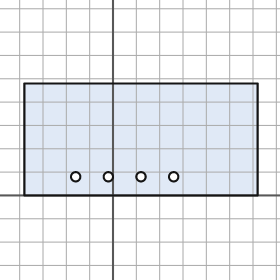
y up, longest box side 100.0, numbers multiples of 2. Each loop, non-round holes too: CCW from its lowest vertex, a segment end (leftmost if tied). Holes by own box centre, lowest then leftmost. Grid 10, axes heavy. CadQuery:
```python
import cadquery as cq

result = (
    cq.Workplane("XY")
    .moveTo(-38.0, 0.0)
    .lineTo(62.0, 0.0)
    .lineTo(62.0, 48.0)
    .lineTo(-38.0, 48.0)
    .close()
    .moveTo(-16.0, 8.0)
    .circle(2.0)
    .moveTo(-2.0, 8.0)
    .circle(2.0)
    .moveTo(12.0, 8.0)
    .circle(2.0)
    .moveTo(26.0, 8.0)
    .circle(2.0)
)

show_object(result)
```